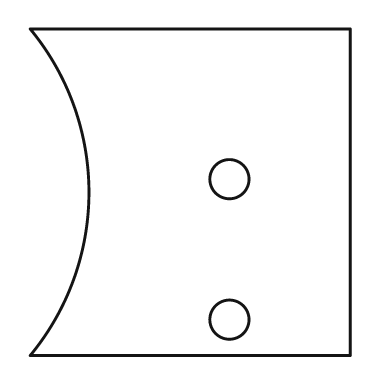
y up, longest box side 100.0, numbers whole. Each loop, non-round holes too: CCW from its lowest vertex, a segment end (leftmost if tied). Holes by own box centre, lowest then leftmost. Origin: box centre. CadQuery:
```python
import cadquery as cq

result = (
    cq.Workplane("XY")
    .moveTo(-49.0, -50.0)
    .lineTo(49.0, -50.0)
    .lineTo(49.0, 50.0)
    .lineTo(-49.0, 50.0)
    .threePointArc((-31.0, 0.0), (-49.0, -50.0))
    .close()
    .moveTo(12.0, -39.0)
    .circle(6.0)
    .moveTo(12.0, 4.0)
    .circle(6.0)
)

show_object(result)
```